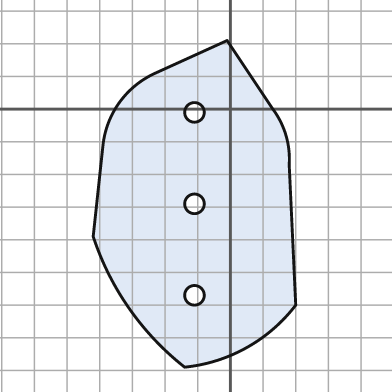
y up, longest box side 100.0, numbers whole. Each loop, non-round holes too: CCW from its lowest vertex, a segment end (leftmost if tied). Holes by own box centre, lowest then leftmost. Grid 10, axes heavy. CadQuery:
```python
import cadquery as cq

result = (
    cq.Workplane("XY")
    .moveTo(-14.0, -79.0)
    .threePointArc((5.0, -73.0), (20.0, -60.0))
    .lineTo(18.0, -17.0)
    .threePointArc((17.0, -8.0), (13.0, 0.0))
    .lineTo(-1.0, 21.0)
    .lineTo(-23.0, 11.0)
    .threePointArc((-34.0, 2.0), (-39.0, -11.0))
    .lineTo(-42.0, -39.0)
    .threePointArc((-31.0, -61.0), (-14.0, -79.0))
    .close()
    .moveTo(-11.0, -57.0)
    .circle(3.0)
    .moveTo(-11.0, -29.0)
    .circle(3.0)
    .moveTo(-11.0, -1.0)
    .circle(3.0)
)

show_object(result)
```